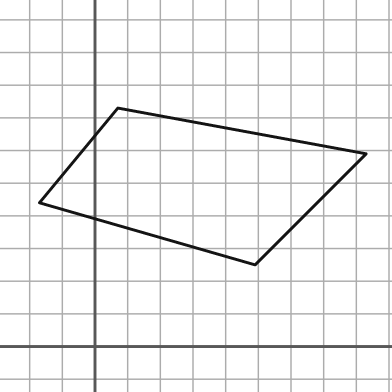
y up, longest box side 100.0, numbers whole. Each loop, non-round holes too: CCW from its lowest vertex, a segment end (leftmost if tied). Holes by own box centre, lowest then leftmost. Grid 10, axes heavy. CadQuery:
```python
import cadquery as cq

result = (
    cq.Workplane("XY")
    .moveTo(49.0, 25.0)
    .lineTo(83.0, 59.0)
    .lineTo(7.0, 73.0)
    .lineTo(-17.0, 44.0)
    .close()
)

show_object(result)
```